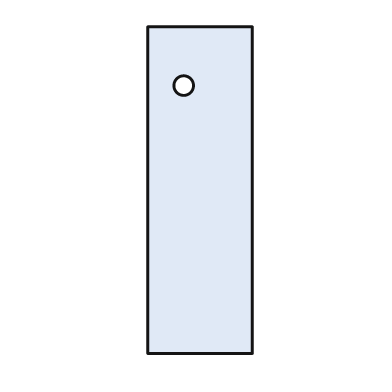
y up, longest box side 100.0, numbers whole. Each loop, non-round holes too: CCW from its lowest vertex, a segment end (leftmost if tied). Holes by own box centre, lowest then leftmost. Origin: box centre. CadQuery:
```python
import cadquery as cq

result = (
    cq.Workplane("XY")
    .moveTo(-16.0, -50.0)
    .lineTo(16.0, -50.0)
    .lineTo(16.0, 50.0)
    .lineTo(-16.0, 50.0)
    .close()
    .moveTo(-5.0, 32.0)
    .circle(3.0)
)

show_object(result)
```